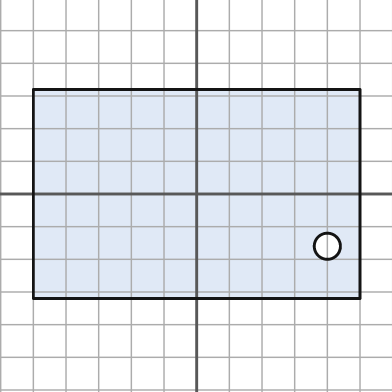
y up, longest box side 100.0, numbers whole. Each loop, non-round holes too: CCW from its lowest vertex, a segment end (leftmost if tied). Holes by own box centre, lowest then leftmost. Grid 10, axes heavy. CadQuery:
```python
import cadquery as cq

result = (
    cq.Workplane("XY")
    .moveTo(-50.0, -32.0)
    .lineTo(50.0, -32.0)
    .lineTo(50.0, 32.0)
    .lineTo(-50.0, 32.0)
    .close()
    .moveTo(40.0, -16.0)
    .circle(4.0)
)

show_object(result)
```